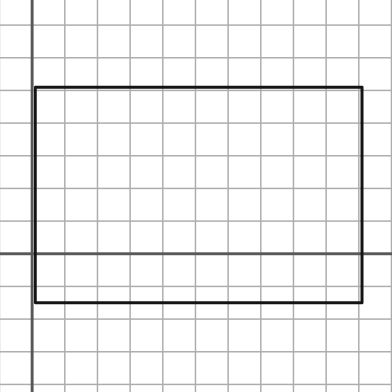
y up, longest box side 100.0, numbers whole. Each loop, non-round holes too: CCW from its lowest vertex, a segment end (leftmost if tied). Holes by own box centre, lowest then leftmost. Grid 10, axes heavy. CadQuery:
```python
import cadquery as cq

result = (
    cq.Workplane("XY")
    .moveTo(1.0, -15.0)
    .lineTo(101.0, -15.0)
    .lineTo(101.0, 51.0)
    .lineTo(1.0, 51.0)
    .close()
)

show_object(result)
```